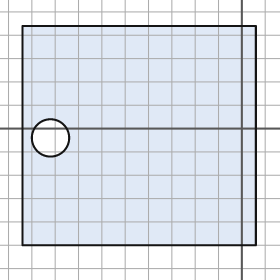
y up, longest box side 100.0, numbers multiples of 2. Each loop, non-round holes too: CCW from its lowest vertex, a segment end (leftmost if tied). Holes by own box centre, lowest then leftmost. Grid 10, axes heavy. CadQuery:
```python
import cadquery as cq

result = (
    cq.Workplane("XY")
    .moveTo(-94.0, -50.0)
    .lineTo(6.0, -50.0)
    .lineTo(6.0, 44.0)
    .lineTo(-94.0, 44.0)
    .close()
    .moveTo(-82.0, -4.0)
    .circle(8.0)
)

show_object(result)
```